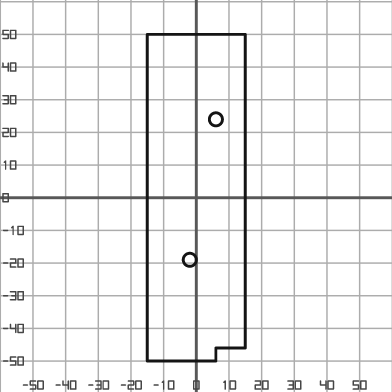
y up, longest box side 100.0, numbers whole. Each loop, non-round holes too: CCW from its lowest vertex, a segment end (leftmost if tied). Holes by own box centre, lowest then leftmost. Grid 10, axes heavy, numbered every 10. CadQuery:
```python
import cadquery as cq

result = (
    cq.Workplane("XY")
    .moveTo(-15.0, -50.0)
    .lineTo(6.0, -50.0)
    .lineTo(6.0, -46.0)
    .lineTo(15.0, -46.0)
    .lineTo(15.0, 50.0)
    .lineTo(-15.0, 50.0)
    .close()
    .moveTo(-2.0, -19.0)
    .circle(2.0)
    .moveTo(6.0, 24.0)
    .circle(2.0)
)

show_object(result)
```